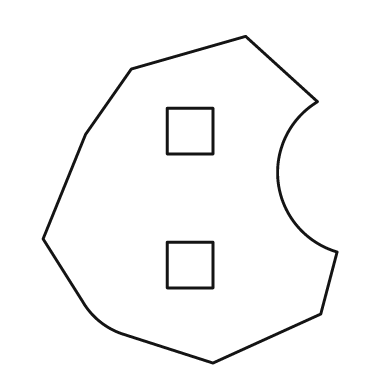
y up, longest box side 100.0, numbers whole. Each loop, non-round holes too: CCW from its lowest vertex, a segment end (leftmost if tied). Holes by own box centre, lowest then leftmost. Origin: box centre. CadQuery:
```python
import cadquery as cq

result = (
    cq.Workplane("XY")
    .moveTo(7.0, -50.0)
    .lineTo(40.0, -35.0)
    .lineTo(45.0, -16.0)
    .threePointArc((27.0, 5.0), (39.0, 30.0))
    .lineTo(17.0, 50.0)
    .lineTo(-18.0, 40.0)
    .lineTo(-32.0, 20.0)
    .lineTo(-45.0, -12.0)
    .lineTo(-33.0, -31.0)
    .threePointArc((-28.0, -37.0), (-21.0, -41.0))
    .close()
    .moveTo(-7.0, -27.0)
    .lineTo(7.0, -27.0)
    .lineTo(7.0, -13.0)
    .lineTo(-7.0, -13.0)
    .close()
    .moveTo(-7.0, 14.0)
    .lineTo(7.0, 14.0)
    .lineTo(7.0, 28.0)
    .lineTo(-7.0, 28.0)
    .close()
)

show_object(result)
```